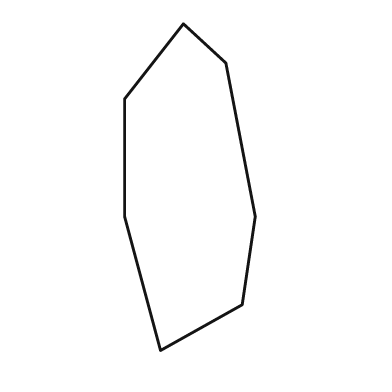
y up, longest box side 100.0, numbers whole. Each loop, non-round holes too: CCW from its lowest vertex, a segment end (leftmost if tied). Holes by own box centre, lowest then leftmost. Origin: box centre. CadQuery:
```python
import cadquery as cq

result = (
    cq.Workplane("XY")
    .moveTo(-9.0, -50.0)
    .lineTo(16.0, -36.0)
    .lineTo(20.0, -9.0)
    .lineTo(11.0, 38.0)
    .lineTo(-2.0, 50.0)
    .lineTo(-20.0, 27.0)
    .lineTo(-20.0, -9.0)
    .close()
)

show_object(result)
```